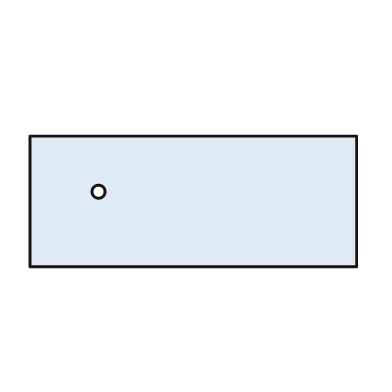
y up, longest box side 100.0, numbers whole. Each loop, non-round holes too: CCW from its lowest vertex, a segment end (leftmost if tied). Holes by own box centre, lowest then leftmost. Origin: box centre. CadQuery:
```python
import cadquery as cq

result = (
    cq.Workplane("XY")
    .moveTo(-50.0, -20.0)
    .lineTo(50.0, -20.0)
    .lineTo(50.0, 20.0)
    .lineTo(-50.0, 20.0)
    .close()
    .moveTo(-29.0, 3.0)
    .circle(2.0)
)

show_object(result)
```